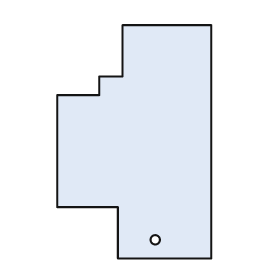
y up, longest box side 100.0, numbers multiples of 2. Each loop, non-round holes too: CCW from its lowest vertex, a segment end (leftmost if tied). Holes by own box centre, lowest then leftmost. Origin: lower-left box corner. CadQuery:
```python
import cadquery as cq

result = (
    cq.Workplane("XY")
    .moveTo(26.0, 0.0)
    .lineTo(66.0, 0.0)
    .lineTo(66.0, 100.0)
    .lineTo(28.0, 100.0)
    .lineTo(28.0, 78.0)
    .lineTo(18.0, 78.0)
    .lineTo(18.0, 70.0)
    .lineTo(0.0, 70.0)
    .lineTo(0.0, 22.0)
    .lineTo(26.0, 22.0)
    .close()
    .moveTo(42.0, 8.0)
    .circle(2.0)
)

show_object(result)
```